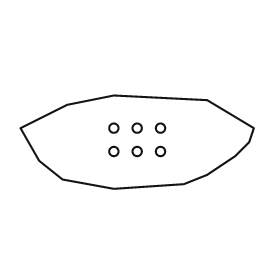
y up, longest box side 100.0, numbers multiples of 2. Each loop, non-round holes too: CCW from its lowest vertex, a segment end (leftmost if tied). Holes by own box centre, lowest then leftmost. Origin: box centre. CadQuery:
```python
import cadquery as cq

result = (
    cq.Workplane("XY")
    .moveTo(-10.0, -20.0)
    .lineTo(20.0, -18.0)
    .lineTo(30.0, -14.0)
    .lineTo(42.0, -6.0)
    .lineTo(48.0, 0.0)
    .lineTo(50.0, 6.0)
    .lineTo(30.0, 18.0)
    .lineTo(-10.0, 20.0)
    .lineTo(-30.0, 16.0)
    .lineTo(-50.0, 6.0)
    .lineTo(-42.0, -8.0)
    .lineTo(-32.0, -16.0)
    .close()
    .moveTo(-10.0, -4.0)
    .circle(2.0)
    .moveTo(0.0, -4.0)
    .circle(2.0)
    .moveTo(10.0, -4.0)
    .circle(2.0)
    .moveTo(-10.0, 6.0)
    .circle(2.0)
    .moveTo(0.0, 6.0)
    .circle(2.0)
    .moveTo(10.0, 6.0)
    .circle(2.0)
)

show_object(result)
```